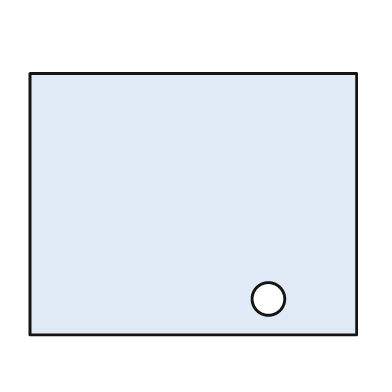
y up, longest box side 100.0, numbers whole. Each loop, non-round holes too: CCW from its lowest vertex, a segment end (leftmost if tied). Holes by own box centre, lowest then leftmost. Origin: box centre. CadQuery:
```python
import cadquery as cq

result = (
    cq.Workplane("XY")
    .moveTo(-50.0, -40.0)
    .lineTo(50.0, -40.0)
    .lineTo(50.0, 40.0)
    .lineTo(-50.0, 40.0)
    .close()
    .moveTo(23.0, -29.0)
    .circle(5.0)
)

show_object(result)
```